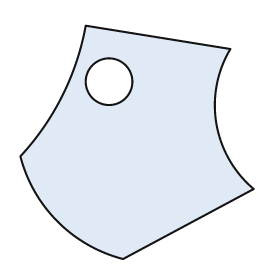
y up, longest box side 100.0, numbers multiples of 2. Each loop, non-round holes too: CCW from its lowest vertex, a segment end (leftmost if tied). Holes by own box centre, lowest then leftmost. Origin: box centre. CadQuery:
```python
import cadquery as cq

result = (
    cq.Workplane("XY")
    .moveTo(-6.0, -50.0)
    .lineTo(50.0, -20.0)
    .threePointArc((34.0, 8.0), (40.0, 40.0))
    .lineTo(-22.0, 50.0)
    .threePointArc((-32.0, 20.0), (-50.0, -6.0))
    .threePointArc((-34.0, -34.0), (-6.0, -50.0))
    .close()
    .moveTo(-12.0, 26.0)
    .circle(10.0)
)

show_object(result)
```